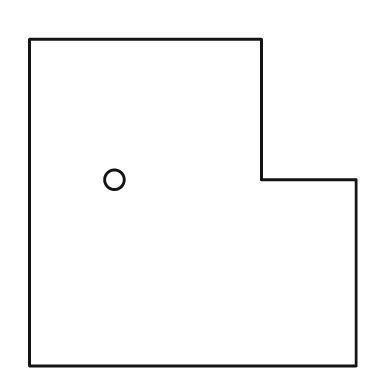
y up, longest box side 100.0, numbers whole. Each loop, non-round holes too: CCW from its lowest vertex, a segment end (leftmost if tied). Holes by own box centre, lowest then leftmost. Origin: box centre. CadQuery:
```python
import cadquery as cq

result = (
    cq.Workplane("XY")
    .moveTo(-50.0, -50.0)
    .lineTo(50.0, -50.0)
    .lineTo(50.0, 7.0)
    .lineTo(21.0, 7.0)
    .lineTo(21.0, 50.0)
    .lineTo(-50.0, 50.0)
    .close()
    .moveTo(-24.0, 7.0)
    .circle(3.0)
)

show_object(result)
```